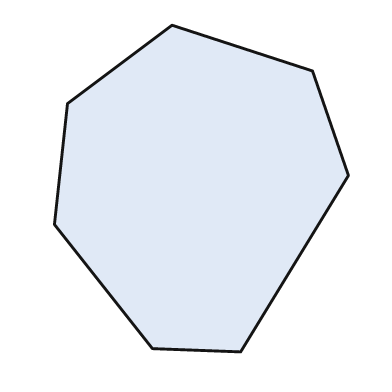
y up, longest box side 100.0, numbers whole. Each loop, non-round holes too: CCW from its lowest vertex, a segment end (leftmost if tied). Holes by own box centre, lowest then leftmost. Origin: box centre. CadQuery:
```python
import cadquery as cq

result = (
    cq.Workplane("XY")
    .moveTo(12.0, -50.0)
    .lineTo(45.0, 4.0)
    .lineTo(34.0, 36.0)
    .lineTo(-9.0, 50.0)
    .lineTo(-41.0, 26.0)
    .lineTo(-45.0, -11.0)
    .lineTo(-15.0, -49.0)
    .close()
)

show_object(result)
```